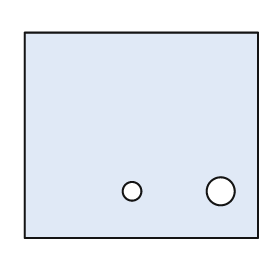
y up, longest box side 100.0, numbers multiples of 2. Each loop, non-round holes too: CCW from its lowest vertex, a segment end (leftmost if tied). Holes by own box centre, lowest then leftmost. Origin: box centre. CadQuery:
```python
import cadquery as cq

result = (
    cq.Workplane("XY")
    .moveTo(-50.0, -44.0)
    .lineTo(50.0, -44.0)
    .lineTo(50.0, 44.0)
    .lineTo(-50.0, 44.0)
    .close()
    .moveTo(-4.0, -24.0)
    .circle(4.0)
    .moveTo(34.0, -24.0)
    .circle(6.0)
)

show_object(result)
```